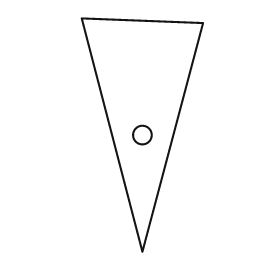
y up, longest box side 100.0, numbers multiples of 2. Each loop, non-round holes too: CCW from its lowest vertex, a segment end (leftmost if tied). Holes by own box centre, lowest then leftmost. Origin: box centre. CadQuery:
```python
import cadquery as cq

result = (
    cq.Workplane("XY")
    .moveTo(0.0, -50.0)
    .lineTo(26.0, 48.0)
    .lineTo(-26.0, 50.0)
    .close()
    .moveTo(0.0, 0.0)
    .circle(4.0)
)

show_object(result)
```